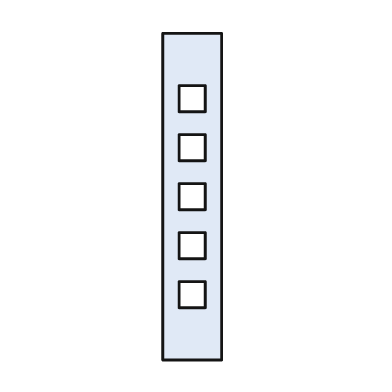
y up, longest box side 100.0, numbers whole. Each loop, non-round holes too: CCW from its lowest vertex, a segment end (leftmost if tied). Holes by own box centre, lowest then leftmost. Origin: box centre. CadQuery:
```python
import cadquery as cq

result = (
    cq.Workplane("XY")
    .moveTo(-9.0, -50.0)
    .lineTo(9.0, -50.0)
    .lineTo(9.0, 50.0)
    .lineTo(-9.0, 50.0)
    .close()
    .moveTo(-4.0, -34.0)
    .lineTo(4.0, -34.0)
    .lineTo(4.0, -26.0)
    .lineTo(-4.0, -26.0)
    .close()
    .moveTo(-4.0, -19.0)
    .lineTo(4.0, -19.0)
    .lineTo(4.0, -11.0)
    .lineTo(-4.0, -11.0)
    .close()
    .moveTo(-4.0, -4.0)
    .lineTo(4.0, -4.0)
    .lineTo(4.0, 4.0)
    .lineTo(-4.0, 4.0)
    .close()
    .moveTo(-4.0, 11.0)
    .lineTo(4.0, 11.0)
    .lineTo(4.0, 19.0)
    .lineTo(-4.0, 19.0)
    .close()
    .moveTo(-4.0, 26.0)
    .lineTo(4.0, 26.0)
    .lineTo(4.0, 34.0)
    .lineTo(-4.0, 34.0)
    .close()
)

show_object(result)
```